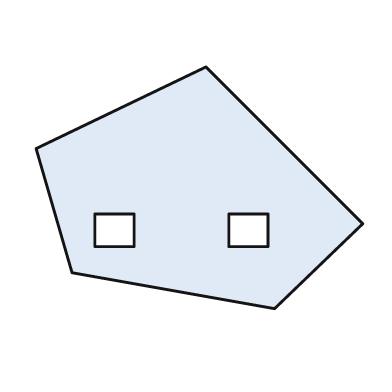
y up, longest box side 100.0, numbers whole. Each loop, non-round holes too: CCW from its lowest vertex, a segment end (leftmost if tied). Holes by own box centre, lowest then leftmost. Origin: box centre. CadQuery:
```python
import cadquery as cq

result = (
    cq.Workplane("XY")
    .moveTo(23.0, -37.0)
    .lineTo(50.0, -11.0)
    .lineTo(2.0, 37.0)
    .lineTo(-50.0, 12.0)
    .lineTo(-39.0, -26.0)
    .close()
    .moveTo(-32.0, -18.0)
    .lineTo(-20.0, -18.0)
    .lineTo(-20.0, -8.0)
    .lineTo(-32.0, -8.0)
    .close()
    .moveTo(9.0, -18.0)
    .lineTo(21.0, -18.0)
    .lineTo(21.0, -8.0)
    .lineTo(9.0, -8.0)
    .close()
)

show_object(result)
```